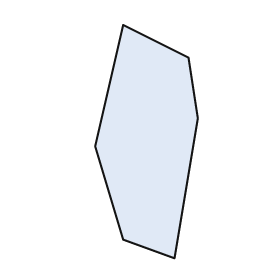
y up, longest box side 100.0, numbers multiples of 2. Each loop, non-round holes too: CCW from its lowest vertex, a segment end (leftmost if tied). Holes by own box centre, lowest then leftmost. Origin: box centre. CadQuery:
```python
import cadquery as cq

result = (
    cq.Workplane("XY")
    .moveTo(12.0, -50.0)
    .lineTo(22.0, 10.0)
    .lineTo(18.0, 36.0)
    .lineTo(-10.0, 50.0)
    .lineTo(-22.0, -2.0)
    .lineTo(-10.0, -42.0)
    .close()
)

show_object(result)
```